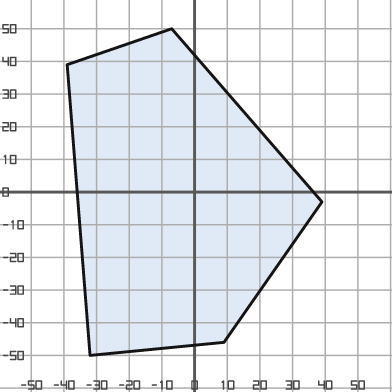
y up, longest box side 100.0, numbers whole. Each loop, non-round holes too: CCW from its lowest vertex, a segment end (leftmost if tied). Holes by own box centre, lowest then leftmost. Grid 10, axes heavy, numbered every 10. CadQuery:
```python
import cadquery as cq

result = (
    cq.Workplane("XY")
    .moveTo(-32.0, -50.0)
    .lineTo(9.0, -46.0)
    .lineTo(39.0, -3.0)
    .lineTo(-7.0, 50.0)
    .lineTo(-39.0, 39.0)
    .close()
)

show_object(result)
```